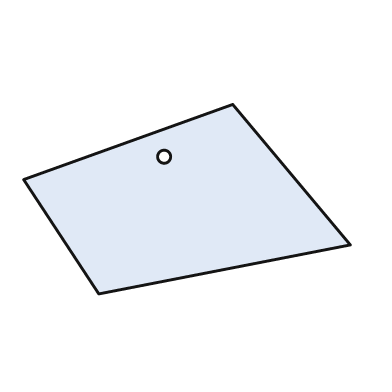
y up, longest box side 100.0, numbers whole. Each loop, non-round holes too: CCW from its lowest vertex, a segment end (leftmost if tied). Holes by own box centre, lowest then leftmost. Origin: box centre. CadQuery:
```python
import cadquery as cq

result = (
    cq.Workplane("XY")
    .moveTo(-27.0, -29.0)
    .lineTo(50.0, -14.0)
    .lineTo(14.0, 29.0)
    .lineTo(-50.0, 6.0)
    .close()
    .moveTo(-7.0, 13.0)
    .circle(2.0)
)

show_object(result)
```